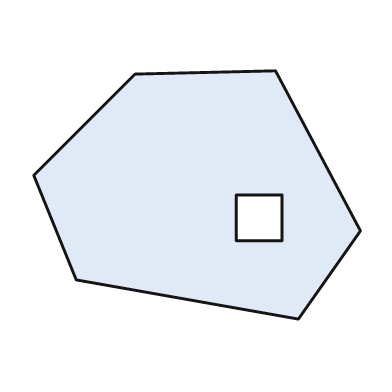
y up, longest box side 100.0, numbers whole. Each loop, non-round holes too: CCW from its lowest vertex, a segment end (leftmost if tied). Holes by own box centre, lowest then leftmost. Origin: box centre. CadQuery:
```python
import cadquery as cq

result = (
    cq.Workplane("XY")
    .moveTo(31.0, -38.0)
    .lineTo(50.0, -11.0)
    .lineTo(24.0, 38.0)
    .lineTo(-19.0, 37.0)
    .lineTo(-50.0, 6.0)
    .lineTo(-37.0, -26.0)
    .close()
    .moveTo(12.0, -14.0)
    .lineTo(26.0, -14.0)
    .lineTo(26.0, 0.0)
    .lineTo(12.0, 0.0)
    .close()
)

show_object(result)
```